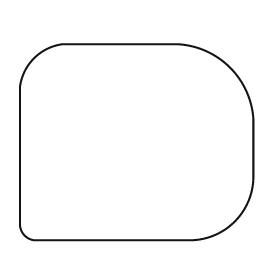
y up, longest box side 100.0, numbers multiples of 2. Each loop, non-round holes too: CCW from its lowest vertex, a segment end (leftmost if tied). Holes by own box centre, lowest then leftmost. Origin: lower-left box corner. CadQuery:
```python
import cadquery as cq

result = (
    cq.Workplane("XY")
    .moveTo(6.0, 0.0)
    .lineTo(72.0, 0.0)
    .threePointArc((92.0, 8.0), (100.0, 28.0))
    .lineTo(100.0, 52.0)
    .threePointArc((90.0, 74.0), (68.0, 84.0))
    .lineTo(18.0, 84.0)
    .threePointArc((6.0, 78.0), (0.0, 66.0))
    .lineTo(0.0, 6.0)
    .threePointArc((2.0, 2.0), (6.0, 0.0))
    .close()
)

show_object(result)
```